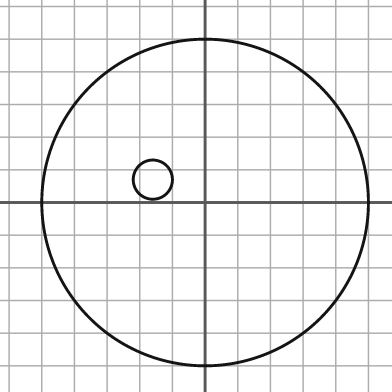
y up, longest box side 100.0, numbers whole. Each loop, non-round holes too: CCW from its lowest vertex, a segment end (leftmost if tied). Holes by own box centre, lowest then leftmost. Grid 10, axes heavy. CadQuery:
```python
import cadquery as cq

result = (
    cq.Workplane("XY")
    .moveTo(0.0, 0.0)
    .circle(50.0)
    .moveTo(-16.0, 7.0)
    .circle(6.0)
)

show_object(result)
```